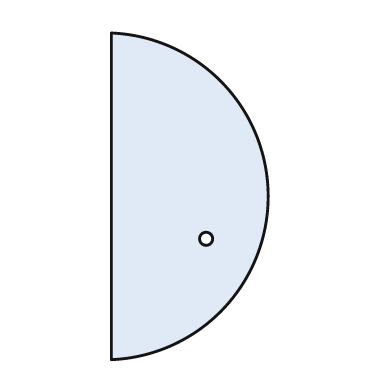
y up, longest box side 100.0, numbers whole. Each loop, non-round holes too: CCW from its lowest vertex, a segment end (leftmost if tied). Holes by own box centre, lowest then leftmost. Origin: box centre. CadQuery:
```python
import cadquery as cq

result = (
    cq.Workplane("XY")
    .moveTo(-24.0, -50.0)
    .threePointArc((24.0, 0.0), (-24.0, 50.0))
    .close()
    .moveTo(5.0, -13.0)
    .circle(2.0)
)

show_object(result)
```